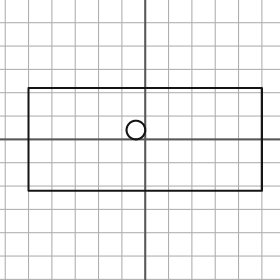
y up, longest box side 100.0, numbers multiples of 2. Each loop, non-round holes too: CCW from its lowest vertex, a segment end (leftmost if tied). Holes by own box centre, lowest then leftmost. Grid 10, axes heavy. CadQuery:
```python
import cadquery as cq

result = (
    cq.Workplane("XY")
    .moveTo(-50.0, -22.0)
    .lineTo(50.0, -22.0)
    .lineTo(50.0, 22.0)
    .lineTo(-50.0, 22.0)
    .close()
    .moveTo(-4.0, 4.0)
    .circle(4.0)
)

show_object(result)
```